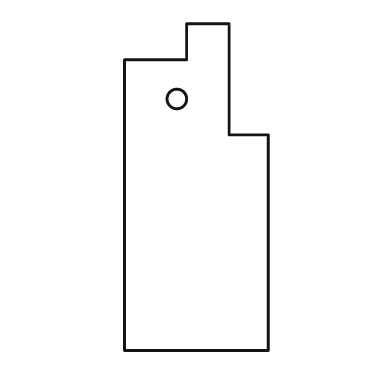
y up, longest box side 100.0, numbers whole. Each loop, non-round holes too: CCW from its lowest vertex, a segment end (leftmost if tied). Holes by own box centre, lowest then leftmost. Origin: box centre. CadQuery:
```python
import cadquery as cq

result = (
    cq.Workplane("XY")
    .moveTo(-22.0, -50.0)
    .lineTo(22.0, -50.0)
    .lineTo(22.0, 16.0)
    .lineTo(10.0, 16.0)
    .lineTo(10.0, 50.0)
    .lineTo(-3.0, 50.0)
    .lineTo(-3.0, 39.0)
    .lineTo(-22.0, 39.0)
    .close()
    .moveTo(-6.0, 27.0)
    .circle(3.0)
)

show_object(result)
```